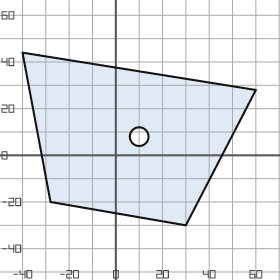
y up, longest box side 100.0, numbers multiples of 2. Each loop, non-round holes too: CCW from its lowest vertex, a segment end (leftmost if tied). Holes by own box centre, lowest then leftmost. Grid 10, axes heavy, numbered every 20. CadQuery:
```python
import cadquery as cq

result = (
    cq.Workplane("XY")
    .moveTo(30.0, -30.0)
    .lineTo(60.0, 28.0)
    .lineTo(-40.0, 44.0)
    .lineTo(-28.0, -20.0)
    .close()
    .moveTo(10.0, 8.0)
    .circle(4.0)
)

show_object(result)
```